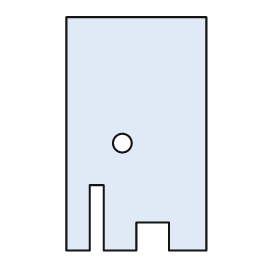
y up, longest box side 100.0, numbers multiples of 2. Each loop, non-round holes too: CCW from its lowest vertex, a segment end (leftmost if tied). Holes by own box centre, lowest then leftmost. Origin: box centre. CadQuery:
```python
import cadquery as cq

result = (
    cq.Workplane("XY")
    .moveTo(-30.0, -50.0)
    .lineTo(-20.0, -50.0)
    .lineTo(-20.0, -22.0)
    .lineTo(-14.0, -22.0)
    .lineTo(-14.0, -50.0)
    .lineTo(0.0, -50.0)
    .lineTo(0.0, -38.0)
    .lineTo(14.0, -38.0)
    .lineTo(14.0, -50.0)
    .lineTo(30.0, -50.0)
    .lineTo(30.0, 50.0)
    .lineTo(-30.0, 50.0)
    .close()
    .moveTo(-6.0, -4.0)
    .circle(4.0)
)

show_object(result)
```